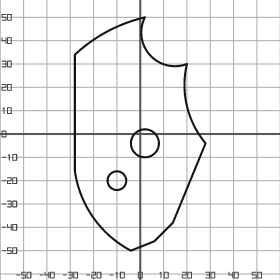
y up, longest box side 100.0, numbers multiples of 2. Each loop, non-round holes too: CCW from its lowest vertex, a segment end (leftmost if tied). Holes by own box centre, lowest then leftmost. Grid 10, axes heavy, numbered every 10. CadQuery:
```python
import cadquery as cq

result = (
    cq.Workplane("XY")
    .moveTo(-4.0, -50.0)
    .lineTo(6.0, -46.0)
    .lineTo(14.0, -38.0)
    .lineTo(28.0, -4.0)
    .threePointArc((20.0, 12.0), (20.0, 30.0))
    .threePointArc((4.0, 34.0), (2.0, 50.0))
    .threePointArc((-14.0, 44.0), (-28.0, 34.0))
    .lineTo(-28.0, -16.0)
    .threePointArc((-20.0, -36.0), (-4.0, -50.0))
    .close()
    .moveTo(-10.0, -20.0)
    .circle(4.0)
    .moveTo(2.0, -4.0)
    .circle(6.0)
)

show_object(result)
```